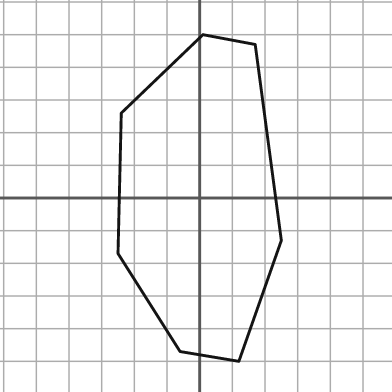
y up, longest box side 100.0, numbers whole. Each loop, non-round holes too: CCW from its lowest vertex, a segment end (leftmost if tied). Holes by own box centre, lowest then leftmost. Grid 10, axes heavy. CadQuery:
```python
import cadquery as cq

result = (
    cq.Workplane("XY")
    .moveTo(12.0, -50.0)
    .lineTo(25.0, -13.0)
    .lineTo(17.0, 47.0)
    .lineTo(1.0, 50.0)
    .lineTo(-24.0, 26.0)
    .lineTo(-25.0, -17.0)
    .lineTo(-6.0, -47.0)
    .close()
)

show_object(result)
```